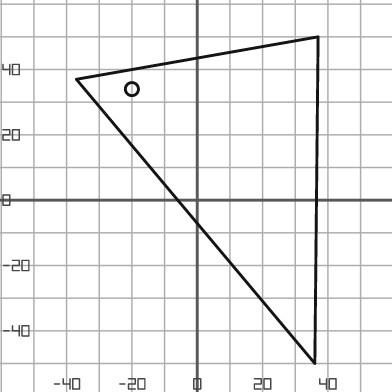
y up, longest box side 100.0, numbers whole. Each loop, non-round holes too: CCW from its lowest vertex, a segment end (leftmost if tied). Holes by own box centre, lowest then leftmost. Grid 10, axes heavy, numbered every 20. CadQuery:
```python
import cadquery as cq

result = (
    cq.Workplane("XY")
    .moveTo(36.0, -50.0)
    .lineTo(37.0, 50.0)
    .lineTo(-37.0, 37.0)
    .close()
    .moveTo(-20.0, 34.0)
    .circle(2.0)
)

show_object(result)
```